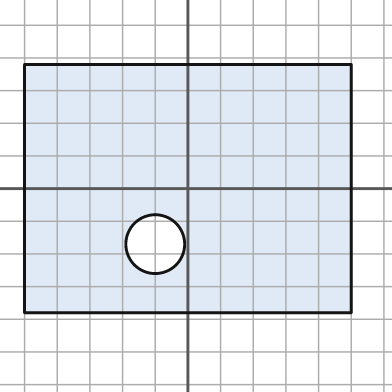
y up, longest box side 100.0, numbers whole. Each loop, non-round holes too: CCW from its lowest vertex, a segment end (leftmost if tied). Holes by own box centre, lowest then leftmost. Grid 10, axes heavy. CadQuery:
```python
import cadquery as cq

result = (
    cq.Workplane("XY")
    .moveTo(-50.0, -38.0)
    .lineTo(50.0, -38.0)
    .lineTo(50.0, 38.0)
    .lineTo(-50.0, 38.0)
    .close()
    .moveTo(-10.0, -17.0)
    .circle(9.0)
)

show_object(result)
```